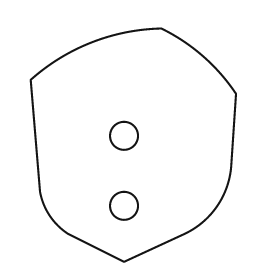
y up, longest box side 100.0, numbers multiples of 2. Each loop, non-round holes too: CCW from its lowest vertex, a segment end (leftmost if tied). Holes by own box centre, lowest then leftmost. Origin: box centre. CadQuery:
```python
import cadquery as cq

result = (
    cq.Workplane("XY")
    .moveTo(-4.0, -50.0)
    .lineTo(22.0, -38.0)
    .threePointArc((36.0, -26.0), (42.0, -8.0))
    .lineTo(44.0, 22.0)
    .threePointArc((30.0, 38.0), (12.0, 50.0))
    .threePointArc((-18.0, 44.0), (-44.0, 28.0))
    .lineTo(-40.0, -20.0)
    .threePointArc((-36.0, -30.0), (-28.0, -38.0))
    .close()
    .moveTo(-4.0, -26.0)
    .circle(6.0)
    .moveTo(-4.0, 4.0)
    .circle(6.0)
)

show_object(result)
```